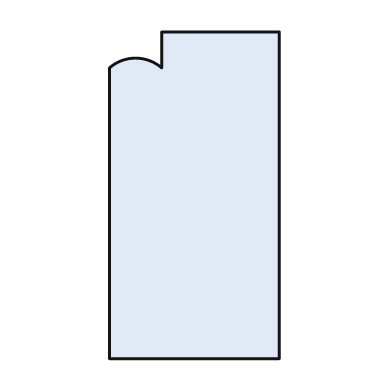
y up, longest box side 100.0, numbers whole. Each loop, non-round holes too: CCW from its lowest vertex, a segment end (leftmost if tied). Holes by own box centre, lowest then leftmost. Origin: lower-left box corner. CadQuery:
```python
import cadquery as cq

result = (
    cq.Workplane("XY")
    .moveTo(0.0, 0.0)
    .lineTo(52.0, 0.0)
    .lineTo(52.0, 100.0)
    .lineTo(16.0, 100.0)
    .lineTo(16.0, 89.0)
    .threePointArc((8.0, 92.0), (0.0, 89.0))
    .close()
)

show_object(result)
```